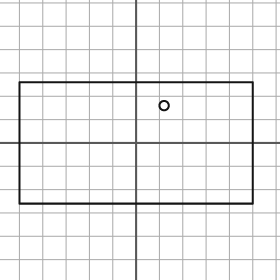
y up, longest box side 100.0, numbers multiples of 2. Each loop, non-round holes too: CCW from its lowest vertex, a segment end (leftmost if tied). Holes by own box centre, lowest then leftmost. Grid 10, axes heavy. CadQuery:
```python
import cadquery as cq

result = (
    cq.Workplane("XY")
    .moveTo(-50.0, -26.0)
    .lineTo(50.0, -26.0)
    .lineTo(50.0, 26.0)
    .lineTo(-50.0, 26.0)
    .close()
    .moveTo(12.0, 16.0)
    .circle(2.0)
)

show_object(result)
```